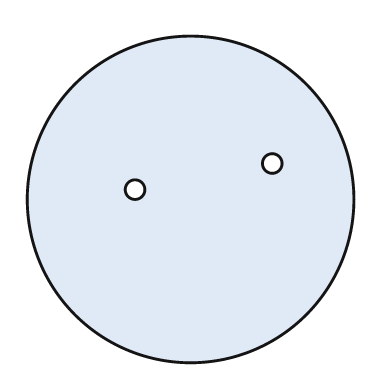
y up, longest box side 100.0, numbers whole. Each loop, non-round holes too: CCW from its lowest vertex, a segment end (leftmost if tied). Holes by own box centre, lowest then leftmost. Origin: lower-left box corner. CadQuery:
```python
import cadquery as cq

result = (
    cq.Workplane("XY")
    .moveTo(50.0, 50.0)
    .circle(50.0)
    .moveTo(33.0, 53.0)
    .circle(3.0)
    .moveTo(75.0, 61.0)
    .circle(3.0)
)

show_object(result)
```